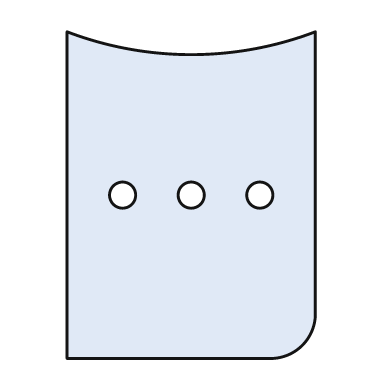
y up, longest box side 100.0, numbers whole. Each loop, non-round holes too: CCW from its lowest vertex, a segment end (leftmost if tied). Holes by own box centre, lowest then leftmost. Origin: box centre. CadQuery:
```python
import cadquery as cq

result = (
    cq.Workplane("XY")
    .moveTo(-38.0, -50.0)
    .lineTo(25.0, -50.0)
    .threePointArc((34.0, -46.0), (38.0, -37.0))
    .lineTo(38.0, 50.0)
    .threePointArc((0.0, 43.0), (-38.0, 50.0))
    .close()
    .moveTo(-21.0, 0.0)
    .circle(4.0)
    .moveTo(0.0, 0.0)
    .circle(4.0)
    .moveTo(21.0, 0.0)
    .circle(4.0)
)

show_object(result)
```